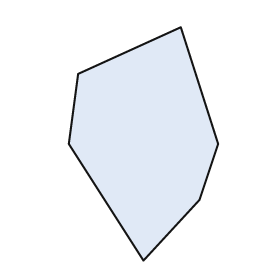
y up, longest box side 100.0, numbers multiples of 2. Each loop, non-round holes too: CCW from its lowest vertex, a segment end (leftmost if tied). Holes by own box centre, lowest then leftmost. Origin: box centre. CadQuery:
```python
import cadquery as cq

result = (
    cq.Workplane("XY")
    .moveTo(0.0, -50.0)
    .lineTo(24.0, -24.0)
    .lineTo(32.0, 0.0)
    .lineTo(16.0, 50.0)
    .lineTo(-28.0, 30.0)
    .lineTo(-32.0, 0.0)
    .close()
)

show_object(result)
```